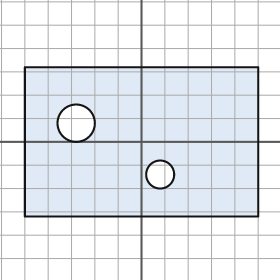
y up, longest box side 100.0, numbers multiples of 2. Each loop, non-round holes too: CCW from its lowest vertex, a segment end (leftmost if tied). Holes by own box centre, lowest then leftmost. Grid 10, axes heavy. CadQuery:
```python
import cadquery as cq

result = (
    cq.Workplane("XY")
    .moveTo(-50.0, -32.0)
    .lineTo(50.0, -32.0)
    .lineTo(50.0, 32.0)
    .lineTo(-50.0, 32.0)
    .close()
    .moveTo(8.0, -14.0)
    .circle(6.0)
    .moveTo(-28.0, 8.0)
    .circle(8.0)
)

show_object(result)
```